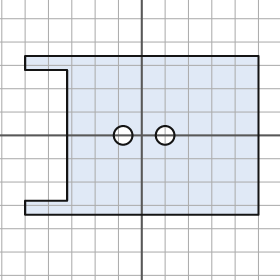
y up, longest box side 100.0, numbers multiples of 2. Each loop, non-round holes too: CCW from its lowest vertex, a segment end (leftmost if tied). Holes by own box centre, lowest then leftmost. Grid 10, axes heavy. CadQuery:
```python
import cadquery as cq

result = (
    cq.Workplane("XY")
    .moveTo(-50.0, -34.0)
    .lineTo(50.0, -34.0)
    .lineTo(50.0, 34.0)
    .lineTo(-50.0, 34.0)
    .lineTo(-50.0, 28.0)
    .lineTo(-32.0, 28.0)
    .lineTo(-32.0, -28.0)
    .lineTo(-50.0, -28.0)
    .close()
    .moveTo(-8.0, 0.0)
    .circle(4.0)
    .moveTo(10.0, 0.0)
    .circle(4.0)
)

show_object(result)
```